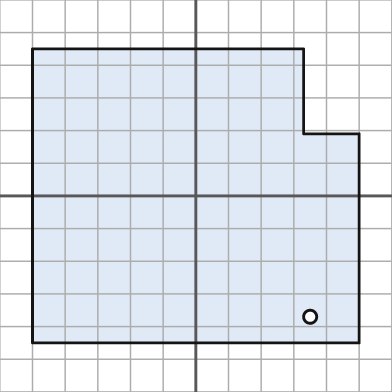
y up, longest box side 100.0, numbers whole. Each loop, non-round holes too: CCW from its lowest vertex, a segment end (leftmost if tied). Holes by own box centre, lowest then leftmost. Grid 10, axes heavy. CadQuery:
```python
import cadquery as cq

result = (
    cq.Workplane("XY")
    .moveTo(-50.0, -45.0)
    .lineTo(50.0, -45.0)
    .lineTo(50.0, 19.0)
    .lineTo(33.0, 19.0)
    .lineTo(33.0, 45.0)
    .lineTo(-50.0, 45.0)
    .close()
    .moveTo(35.0, -37.0)
    .circle(2.0)
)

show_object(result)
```